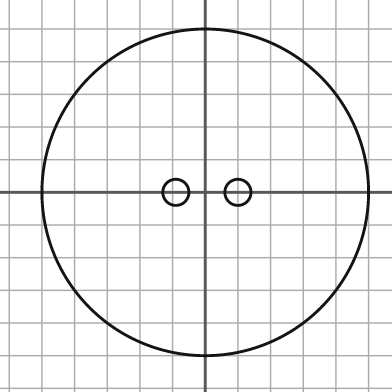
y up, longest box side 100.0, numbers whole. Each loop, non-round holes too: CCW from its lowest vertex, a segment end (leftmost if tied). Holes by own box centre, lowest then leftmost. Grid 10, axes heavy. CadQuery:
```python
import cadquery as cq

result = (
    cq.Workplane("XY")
    .moveTo(0.0, 0.0)
    .circle(50.0)
    .moveTo(-9.0, 0.0)
    .circle(4.0)
    .moveTo(10.0, 0.0)
    .circle(4.0)
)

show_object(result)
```